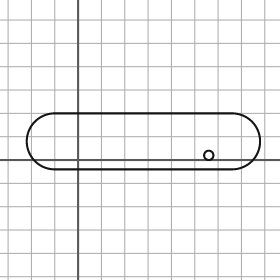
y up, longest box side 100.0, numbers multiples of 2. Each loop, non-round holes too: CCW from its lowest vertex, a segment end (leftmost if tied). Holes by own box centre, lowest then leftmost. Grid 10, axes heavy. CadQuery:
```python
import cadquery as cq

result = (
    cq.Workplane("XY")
    .moveTo(-10.0, -4.0)
    .lineTo(66.0, -4.0)
    .threePointArc((78.0, 8.0), (66.0, 20.0))
    .lineTo(-10.0, 20.0)
    .threePointArc((-22.0, 8.0), (-10.0, -4.0))
    .close()
    .moveTo(56.0, 2.0)
    .circle(2.0)
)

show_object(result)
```